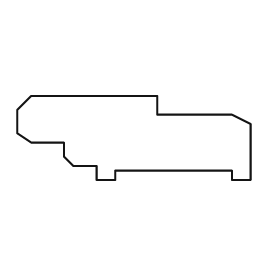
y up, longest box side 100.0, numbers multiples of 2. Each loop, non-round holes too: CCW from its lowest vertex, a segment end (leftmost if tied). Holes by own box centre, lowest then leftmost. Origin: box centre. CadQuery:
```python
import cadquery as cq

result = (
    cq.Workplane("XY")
    .moveTo(-16.0, -18.0)
    .lineTo(-8.0, -18.0)
    .lineTo(-8.0, -14.0)
    .lineTo(42.0, -14.0)
    .lineTo(42.0, -18.0)
    .lineTo(50.0, -18.0)
    .lineTo(50.0, 6.0)
    .lineTo(42.0, 10.0)
    .lineTo(10.0, 10.0)
    .lineTo(10.0, 18.0)
    .lineTo(-44.0, 18.0)
    .lineTo(-50.0, 12.0)
    .lineTo(-50.0, 2.0)
    .lineTo(-44.0, -2.0)
    .lineTo(-30.0, -2.0)
    .lineTo(-30.0, -8.0)
    .lineTo(-26.0, -12.0)
    .lineTo(-16.0, -12.0)
    .close()
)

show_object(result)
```